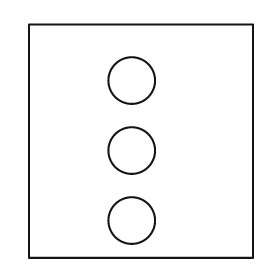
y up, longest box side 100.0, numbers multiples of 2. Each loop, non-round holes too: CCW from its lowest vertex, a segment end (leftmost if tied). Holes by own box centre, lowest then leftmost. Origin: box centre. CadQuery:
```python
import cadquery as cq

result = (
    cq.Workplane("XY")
    .moveTo(-48.0, -50.0)
    .lineTo(48.0, -50.0)
    .lineTo(48.0, 50.0)
    .lineTo(-48.0, 50.0)
    .close()
    .moveTo(-4.0, -34.0)
    .circle(10.0)
    .moveTo(-4.0, -4.0)
    .circle(10.0)
    .moveTo(-4.0, 26.0)
    .circle(10.0)
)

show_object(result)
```